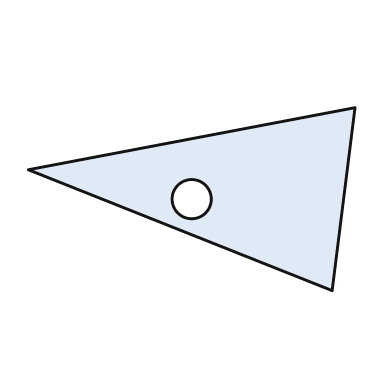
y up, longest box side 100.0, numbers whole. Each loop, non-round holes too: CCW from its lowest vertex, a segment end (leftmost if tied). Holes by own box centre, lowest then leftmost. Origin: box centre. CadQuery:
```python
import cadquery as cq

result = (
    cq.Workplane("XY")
    .moveTo(43.0, -28.0)
    .lineTo(50.0, 28.0)
    .lineTo(-50.0, 9.0)
    .close()
    .moveTo(0.0, 0.0)
    .circle(6.0)
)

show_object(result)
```